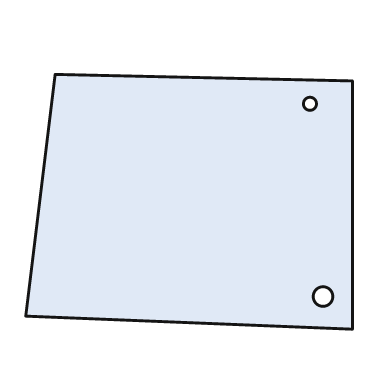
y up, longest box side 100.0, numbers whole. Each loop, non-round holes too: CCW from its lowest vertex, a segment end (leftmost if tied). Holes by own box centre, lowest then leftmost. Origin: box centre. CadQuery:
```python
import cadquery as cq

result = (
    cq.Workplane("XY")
    .moveTo(50.0, -39.0)
    .lineTo(50.0, 37.0)
    .lineTo(-41.0, 39.0)
    .lineTo(-50.0, -35.0)
    .close()
    .moveTo(41.0, -29.0)
    .circle(3.0)
    .moveTo(37.0, 30.0)
    .circle(2.0)
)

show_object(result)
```